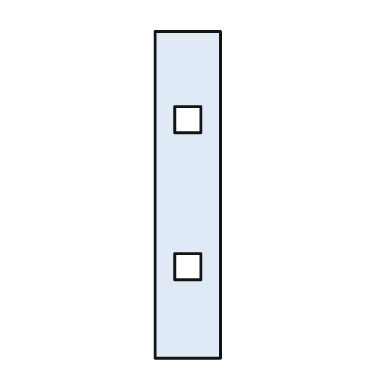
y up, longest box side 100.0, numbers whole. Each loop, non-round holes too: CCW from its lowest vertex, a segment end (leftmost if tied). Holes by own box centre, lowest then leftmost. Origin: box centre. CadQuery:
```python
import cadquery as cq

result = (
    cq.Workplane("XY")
    .moveTo(-10.0, -50.0)
    .lineTo(10.0, -50.0)
    .lineTo(10.0, 50.0)
    .lineTo(-10.0, 50.0)
    .close()
    .moveTo(-4.0, -26.0)
    .lineTo(4.0, -26.0)
    .lineTo(4.0, -18.0)
    .lineTo(-4.0, -18.0)
    .close()
    .moveTo(-4.0, 19.0)
    .lineTo(4.0, 19.0)
    .lineTo(4.0, 27.0)
    .lineTo(-4.0, 27.0)
    .close()
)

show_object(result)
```